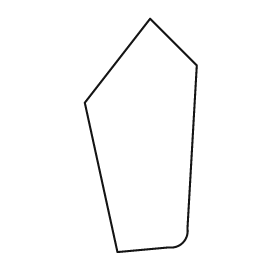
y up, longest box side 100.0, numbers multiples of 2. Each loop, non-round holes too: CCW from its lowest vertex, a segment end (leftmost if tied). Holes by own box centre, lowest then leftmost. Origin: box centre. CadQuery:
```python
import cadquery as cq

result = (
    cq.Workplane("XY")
    .moveTo(-10.0, -50.0)
    .lineTo(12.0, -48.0)
    .threePointArc((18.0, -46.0), (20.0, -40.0))
    .lineTo(24.0, 30.0)
    .lineTo(4.0, 50.0)
    .lineTo(-24.0, 14.0)
    .close()
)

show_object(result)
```